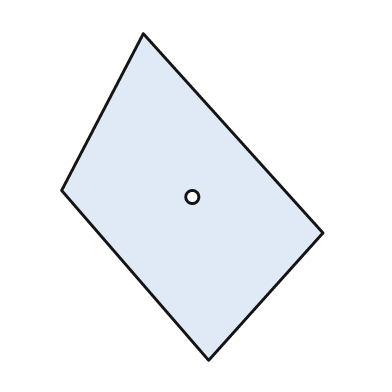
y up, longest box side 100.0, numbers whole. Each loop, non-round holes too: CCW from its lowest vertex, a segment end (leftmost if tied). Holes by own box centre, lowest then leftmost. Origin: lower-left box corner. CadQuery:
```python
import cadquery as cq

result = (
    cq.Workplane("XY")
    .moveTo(45.0, 0.0)
    .lineTo(80.0, 39.0)
    .lineTo(25.0, 100.0)
    .lineTo(0.0, 52.0)
    .close()
    .moveTo(40.0, 50.0)
    .circle(2.0)
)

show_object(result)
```